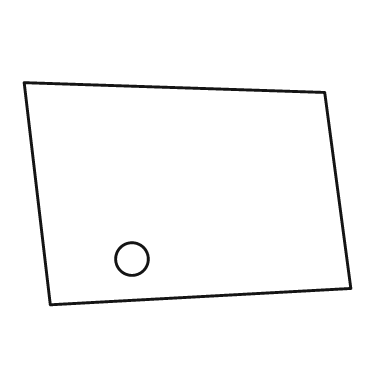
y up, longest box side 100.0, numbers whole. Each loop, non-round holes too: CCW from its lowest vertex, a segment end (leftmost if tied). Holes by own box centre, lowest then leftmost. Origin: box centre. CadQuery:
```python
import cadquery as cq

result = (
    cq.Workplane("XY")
    .moveTo(-42.0, -34.0)
    .lineTo(50.0, -29.0)
    .lineTo(42.0, 31.0)
    .lineTo(-50.0, 34.0)
    .close()
    .moveTo(-17.0, -20.0)
    .circle(5.0)
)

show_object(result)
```